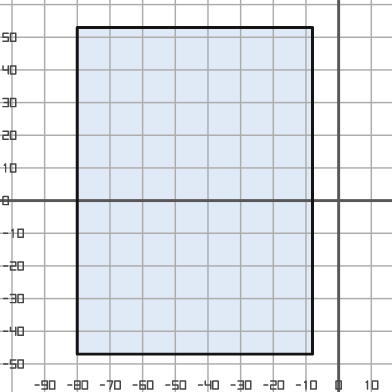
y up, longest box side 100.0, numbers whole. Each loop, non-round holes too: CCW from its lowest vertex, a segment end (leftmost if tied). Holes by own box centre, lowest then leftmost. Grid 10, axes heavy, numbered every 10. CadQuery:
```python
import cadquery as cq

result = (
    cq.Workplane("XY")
    .moveTo(-80.0, -47.0)
    .lineTo(-8.0, -47.0)
    .lineTo(-8.0, 53.0)
    .lineTo(-80.0, 53.0)
    .close()
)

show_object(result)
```